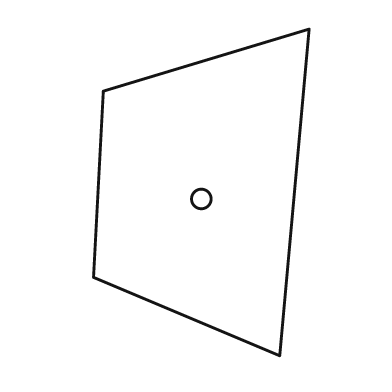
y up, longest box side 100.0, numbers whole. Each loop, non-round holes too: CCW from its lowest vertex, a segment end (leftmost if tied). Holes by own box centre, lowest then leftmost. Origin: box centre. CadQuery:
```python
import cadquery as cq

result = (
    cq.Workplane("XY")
    .moveTo(24.0, -50.0)
    .lineTo(33.0, 50.0)
    .lineTo(-30.0, 31.0)
    .lineTo(-33.0, -26.0)
    .close()
    .moveTo(0.0, -2.0)
    .circle(3.0)
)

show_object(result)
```